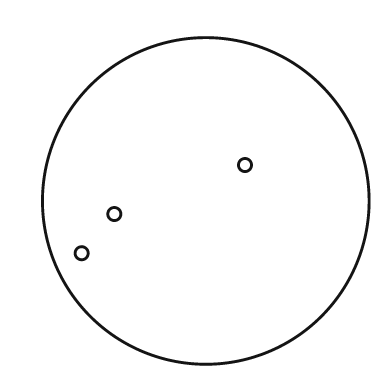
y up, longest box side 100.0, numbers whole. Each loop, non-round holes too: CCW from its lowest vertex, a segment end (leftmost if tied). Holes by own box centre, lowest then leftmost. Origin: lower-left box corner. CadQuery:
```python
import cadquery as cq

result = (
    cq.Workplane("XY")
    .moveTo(50.0, 50.0)
    .circle(50.0)
    .moveTo(12.0, 34.0)
    .circle(2.0)
    .moveTo(22.0, 46.0)
    .circle(2.0)
    .moveTo(62.0, 61.0)
    .circle(2.0)
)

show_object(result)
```